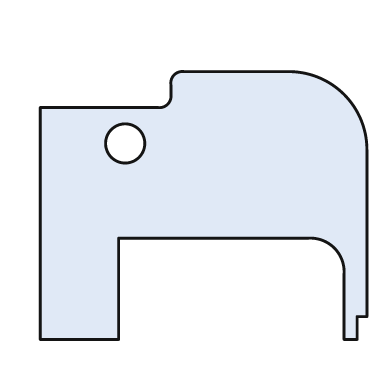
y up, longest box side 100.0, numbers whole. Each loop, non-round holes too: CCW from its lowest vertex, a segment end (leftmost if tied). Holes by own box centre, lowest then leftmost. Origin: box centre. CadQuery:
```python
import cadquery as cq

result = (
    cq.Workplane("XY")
    .moveTo(-50.0, -41.0)
    .lineTo(-26.0, -41.0)
    .lineTo(-26.0, -10.0)
    .lineTo(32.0, -10.0)
    .threePointArc((40.0, -13.0), (43.0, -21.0))
    .lineTo(43.0, -41.0)
    .lineTo(47.0, -41.0)
    .lineTo(47.0, -34.0)
    .lineTo(50.0, -34.0)
    .lineTo(50.0, 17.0)
    .threePointArc((43.0, 34.0), (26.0, 41.0))
    .lineTo(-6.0, 41.0)
    .threePointArc((-9.0, 40.0), (-10.0, 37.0))
    .lineTo(-10.0, 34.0)
    .threePointArc((-11.0, 31.0), (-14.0, 30.0))
    .lineTo(-50.0, 30.0)
    .close()
    .moveTo(-24.0, 19.0)
    .circle(6.0)
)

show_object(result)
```